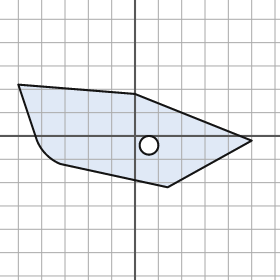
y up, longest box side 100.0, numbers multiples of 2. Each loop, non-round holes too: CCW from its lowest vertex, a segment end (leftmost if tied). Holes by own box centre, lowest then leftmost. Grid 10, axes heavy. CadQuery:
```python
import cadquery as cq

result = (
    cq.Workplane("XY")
    .moveTo(14.0, -22.0)
    .lineTo(50.0, -2.0)
    .lineTo(0.0, 18.0)
    .lineTo(-50.0, 22.0)
    .lineTo(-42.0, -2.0)
    .threePointArc((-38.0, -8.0), (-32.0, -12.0))
    .close()
    .moveTo(6.0, -4.0)
    .circle(4.0)
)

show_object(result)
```